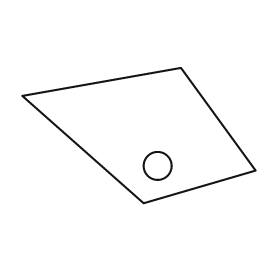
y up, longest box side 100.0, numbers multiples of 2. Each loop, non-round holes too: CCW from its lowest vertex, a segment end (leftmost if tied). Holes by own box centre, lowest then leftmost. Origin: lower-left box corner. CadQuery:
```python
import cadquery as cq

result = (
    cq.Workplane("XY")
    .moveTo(52.0, 0.0)
    .lineTo(100.0, 14.0)
    .lineTo(68.0, 58.0)
    .lineTo(0.0, 46.0)
    .close()
    .moveTo(58.0, 16.0)
    .circle(6.0)
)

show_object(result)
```